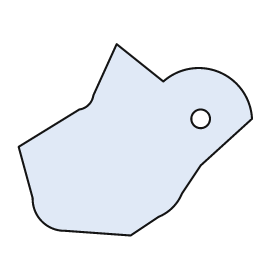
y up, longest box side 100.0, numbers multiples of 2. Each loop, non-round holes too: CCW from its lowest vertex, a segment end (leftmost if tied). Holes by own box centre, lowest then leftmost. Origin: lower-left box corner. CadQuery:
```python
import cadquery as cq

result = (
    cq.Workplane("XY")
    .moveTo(48.0, 0.0)
    .lineTo(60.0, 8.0)
    .threePointArc((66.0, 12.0), (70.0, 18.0))
    .lineTo(78.0, 30.0)
    .lineTo(100.0, 50.0)
    .threePointArc((86.0, 70.0), (62.0, 66.0))
    .lineTo(42.0, 82.0)
    .lineTo(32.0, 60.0)
    .threePointArc((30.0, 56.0), (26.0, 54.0))
    .lineTo(0.0, 38.0)
    .lineTo(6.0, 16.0)
    .threePointArc((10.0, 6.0), (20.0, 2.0))
    .close()
    .moveTo(78.0, 50.0)
    .circle(4.0)
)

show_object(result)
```